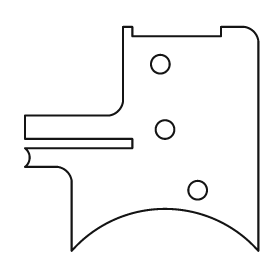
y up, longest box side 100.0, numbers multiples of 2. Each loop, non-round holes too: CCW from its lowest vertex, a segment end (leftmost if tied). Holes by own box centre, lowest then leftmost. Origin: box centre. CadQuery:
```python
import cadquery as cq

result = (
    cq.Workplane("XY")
    .moveTo(-30.0, -48.0)
    .threePointArc((10.0, -30.0), (50.0, -48.0))
    .lineTo(50.0, 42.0)
    .threePointArc((48.0, 46.0), (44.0, 48.0))
    .lineTo(34.0, 48.0)
    .lineTo(34.0, 44.0)
    .lineTo(-4.0, 44.0)
    .lineTo(-4.0, 48.0)
    .lineTo(-8.0, 48.0)
    .lineTo(-8.0, 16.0)
    .threePointArc((-10.0, 12.0), (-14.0, 10.0))
    .lineTo(-50.0, 10.0)
    .lineTo(-50.0, 0.0)
    .lineTo(-4.0, 0.0)
    .lineTo(-4.0, -4.0)
    .lineTo(-50.0, -4.0)
    .threePointArc((-48.0, -8.0), (-50.0, -12.0))
    .lineTo(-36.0, -12.0)
    .threePointArc((-32.0, -14.0), (-30.0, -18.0))
    .close()
    .moveTo(24.0, -22.0)
    .circle(4.0)
    .moveTo(10.0, 4.0)
    .circle(4.0)
    .moveTo(8.0, 32.0)
    .circle(4.0)
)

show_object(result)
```